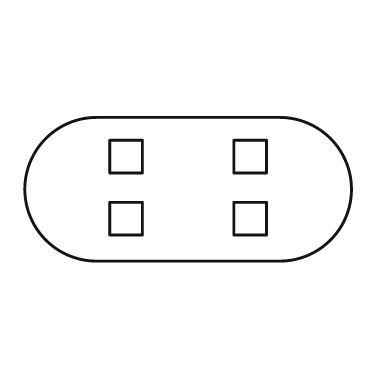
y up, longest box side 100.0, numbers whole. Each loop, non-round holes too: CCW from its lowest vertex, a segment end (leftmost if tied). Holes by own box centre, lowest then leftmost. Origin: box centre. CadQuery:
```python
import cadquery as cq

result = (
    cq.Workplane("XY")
    .moveTo(-28.0, -22.0)
    .lineTo(28.0, -22.0)
    .threePointArc((50.0, 0.0), (28.0, 22.0))
    .lineTo(-28.0, 22.0)
    .threePointArc((-50.0, 0.0), (-28.0, -22.0))
    .close()
    .moveTo(-24.0, -14.0)
    .lineTo(-14.0, -14.0)
    .lineTo(-14.0, -4.0)
    .lineTo(-24.0, -4.0)
    .close()
    .moveTo(14.0, -14.0)
    .lineTo(24.0, -14.0)
    .lineTo(24.0, -4.0)
    .lineTo(14.0, -4.0)
    .close()
    .moveTo(-24.0, 5.0)
    .lineTo(-14.0, 5.0)
    .lineTo(-14.0, 15.0)
    .lineTo(-24.0, 15.0)
    .close()
    .moveTo(14.0, 5.0)
    .lineTo(24.0, 5.0)
    .lineTo(24.0, 15.0)
    .lineTo(14.0, 15.0)
    .close()
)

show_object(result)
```